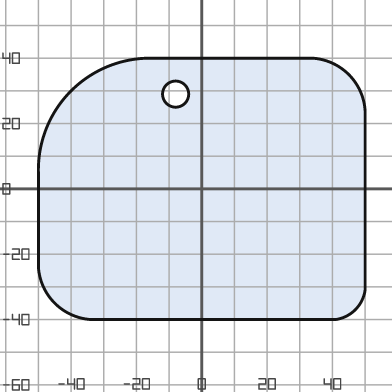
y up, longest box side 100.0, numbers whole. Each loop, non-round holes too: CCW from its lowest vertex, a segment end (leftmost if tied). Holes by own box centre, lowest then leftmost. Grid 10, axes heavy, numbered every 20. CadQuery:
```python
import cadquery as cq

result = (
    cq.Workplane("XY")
    .moveTo(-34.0, -40.0)
    .lineTo(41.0, -40.0)
    .threePointArc((47.0, -37.0), (50.0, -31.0))
    .lineTo(50.0, 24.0)
    .threePointArc((45.0, 35.0), (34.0, 40.0))
    .lineTo(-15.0, 40.0)
    .threePointArc((-40.0, 30.0), (-50.0, 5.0))
    .lineTo(-50.0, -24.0)
    .threePointArc((-45.0, -35.0), (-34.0, -40.0))
    .close()
    .moveTo(-8.0, 29.0)
    .circle(4.0)
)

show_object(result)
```